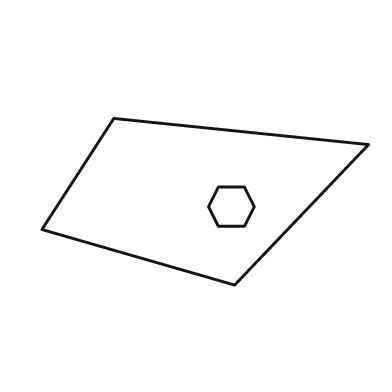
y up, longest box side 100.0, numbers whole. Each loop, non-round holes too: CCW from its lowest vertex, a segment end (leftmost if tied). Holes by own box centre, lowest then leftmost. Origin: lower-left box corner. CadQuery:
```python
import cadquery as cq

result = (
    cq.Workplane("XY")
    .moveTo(59.0, 0.0)
    .lineTo(100.0, 43.0)
    .lineTo(22.0, 51.0)
    .lineTo(0.0, 17.0)
    .close()
    .moveTo(54.0, 18.0)
    .lineTo(62.0, 18.0)
    .lineTo(65.0, 24.0)
    .lineTo(62.0, 30.0)
    .lineTo(54.0, 30.0)
    .lineTo(51.0, 24.0)
    .close()
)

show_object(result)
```